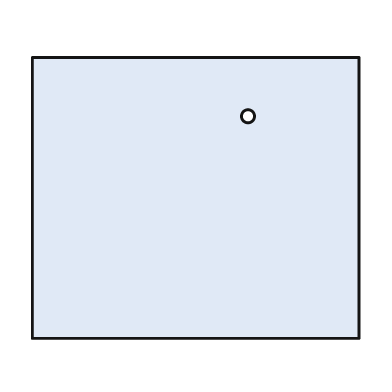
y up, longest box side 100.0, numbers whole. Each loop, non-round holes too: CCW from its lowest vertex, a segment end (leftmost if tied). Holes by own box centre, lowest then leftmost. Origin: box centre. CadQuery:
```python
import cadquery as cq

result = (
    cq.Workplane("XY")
    .moveTo(-50.0, -43.0)
    .lineTo(50.0, -43.0)
    .lineTo(50.0, 43.0)
    .lineTo(-50.0, 43.0)
    .close()
    .moveTo(16.0, 25.0)
    .circle(2.0)
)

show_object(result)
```